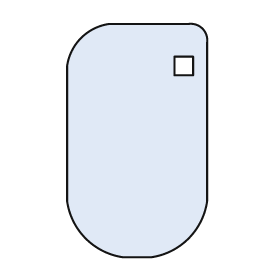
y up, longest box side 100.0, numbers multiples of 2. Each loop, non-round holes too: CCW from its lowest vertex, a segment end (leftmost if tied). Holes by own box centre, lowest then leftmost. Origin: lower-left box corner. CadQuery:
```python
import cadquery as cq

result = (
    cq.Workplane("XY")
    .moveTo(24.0, 0.0)
    .lineTo(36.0, 0.0)
    .threePointArc((52.0, 8.0), (60.0, 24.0))
    .lineTo(60.0, 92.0)
    .threePointArc((58.0, 98.0), (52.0, 100.0))
    .lineTo(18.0, 100.0)
    .threePointArc((6.0, 94.0), (0.0, 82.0))
    .lineTo(0.0, 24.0)
    .threePointArc((8.0, 8.0), (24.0, 0.0))
    .close()
    .moveTo(46.0, 78.0)
    .lineTo(54.0, 78.0)
    .lineTo(54.0, 86.0)
    .lineTo(46.0, 86.0)
    .close()
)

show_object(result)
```